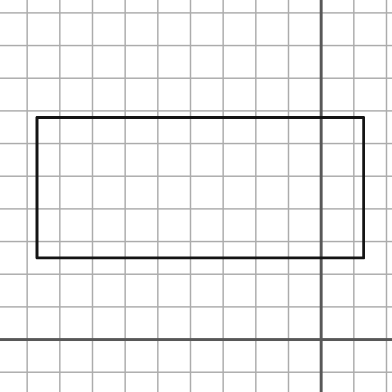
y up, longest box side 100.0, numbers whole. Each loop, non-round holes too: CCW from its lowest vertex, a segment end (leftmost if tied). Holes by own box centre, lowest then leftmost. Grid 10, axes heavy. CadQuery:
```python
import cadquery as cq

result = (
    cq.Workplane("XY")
    .moveTo(-87.0, 25.0)
    .lineTo(13.0, 25.0)
    .lineTo(13.0, 68.0)
    .lineTo(-87.0, 68.0)
    .close()
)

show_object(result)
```